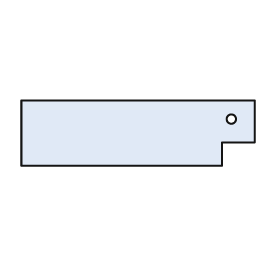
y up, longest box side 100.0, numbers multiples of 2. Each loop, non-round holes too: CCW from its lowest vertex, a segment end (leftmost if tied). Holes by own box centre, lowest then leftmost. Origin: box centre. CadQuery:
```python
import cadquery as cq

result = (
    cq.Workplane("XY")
    .moveTo(-50.0, -14.0)
    .lineTo(36.0, -14.0)
    .lineTo(36.0, -4.0)
    .lineTo(50.0, -4.0)
    .lineTo(50.0, 14.0)
    .lineTo(-50.0, 14.0)
    .close()
    .moveTo(40.0, 6.0)
    .circle(2.0)
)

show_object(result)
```